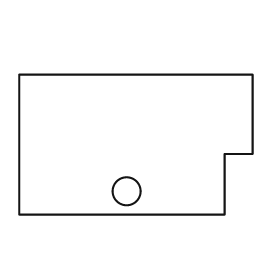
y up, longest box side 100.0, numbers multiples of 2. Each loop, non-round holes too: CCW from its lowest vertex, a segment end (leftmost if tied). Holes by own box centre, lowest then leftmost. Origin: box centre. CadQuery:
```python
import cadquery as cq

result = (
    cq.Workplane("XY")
    .moveTo(-50.0, -30.0)
    .lineTo(38.0, -30.0)
    .lineTo(38.0, -4.0)
    .lineTo(50.0, -4.0)
    .lineTo(50.0, 30.0)
    .lineTo(-50.0, 30.0)
    .close()
    .moveTo(-4.0, -20.0)
    .circle(6.0)
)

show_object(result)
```